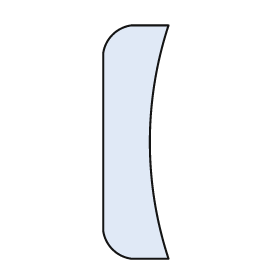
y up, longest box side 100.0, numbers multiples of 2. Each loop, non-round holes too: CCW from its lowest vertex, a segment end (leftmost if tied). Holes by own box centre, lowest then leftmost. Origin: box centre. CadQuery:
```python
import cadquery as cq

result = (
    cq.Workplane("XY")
    .moveTo(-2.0, -50.0)
    .lineTo(14.0, -50.0)
    .threePointArc((6.0, 0.0), (14.0, 50.0))
    .lineTo(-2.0, 50.0)
    .threePointArc((-10.0, 46.0), (-14.0, 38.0))
    .lineTo(-14.0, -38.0)
    .threePointArc((-10.0, -46.0), (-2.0, -50.0))
    .close()
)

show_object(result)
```